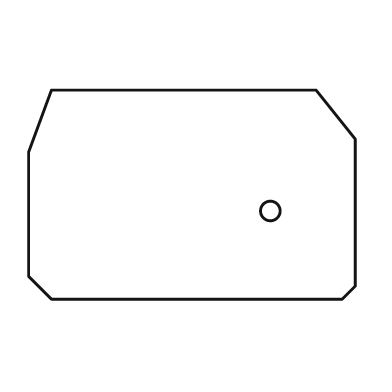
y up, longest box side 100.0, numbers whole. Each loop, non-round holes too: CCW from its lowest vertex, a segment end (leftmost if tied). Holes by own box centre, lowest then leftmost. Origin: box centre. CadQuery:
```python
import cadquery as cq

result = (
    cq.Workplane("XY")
    .moveTo(-43.0, -32.0)
    .lineTo(46.0, -32.0)
    .lineTo(50.0, -28.0)
    .lineTo(50.0, 17.0)
    .lineTo(38.0, 32.0)
    .lineTo(-43.0, 32.0)
    .lineTo(-50.0, 13.0)
    .lineTo(-50.0, -25.0)
    .close()
    .moveTo(24.0, -5.0)
    .circle(3.0)
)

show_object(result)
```